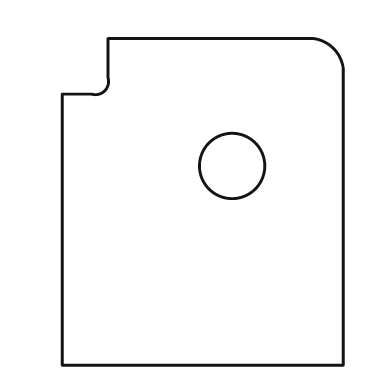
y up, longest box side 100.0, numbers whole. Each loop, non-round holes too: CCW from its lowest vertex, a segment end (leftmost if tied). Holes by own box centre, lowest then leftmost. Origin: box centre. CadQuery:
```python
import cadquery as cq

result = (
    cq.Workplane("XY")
    .moveTo(-43.0, -50.0)
    .lineTo(43.0, -50.0)
    .lineTo(43.0, 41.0)
    .threePointArc((40.0, 47.0), (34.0, 50.0))
    .lineTo(-29.0, 50.0)
    .lineTo(-29.0, 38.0)
    .threePointArc((-30.0, 34.0), (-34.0, 33.0))
    .lineTo(-43.0, 33.0)
    .close()
    .moveTo(9.0, 11.0)
    .circle(10.0)
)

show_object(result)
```